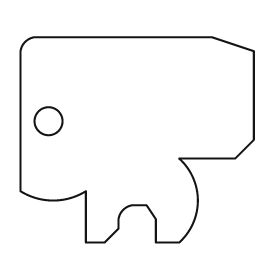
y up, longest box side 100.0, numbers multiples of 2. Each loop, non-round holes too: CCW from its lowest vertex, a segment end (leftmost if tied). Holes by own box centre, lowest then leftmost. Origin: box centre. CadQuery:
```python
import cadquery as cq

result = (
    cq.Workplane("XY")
    .moveTo(-22.0, -44.0)
    .lineTo(-14.0, -44.0)
    .lineTo(-8.0, -38.0)
    .lineTo(-8.0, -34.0)
    .threePointArc((-6.0, -30.0), (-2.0, -28.0))
    .lineTo(4.0, -28.0)
    .lineTo(8.0, -34.0)
    .lineTo(8.0, -44.0)
    .lineTo(18.0, -44.0)
    .threePointArc((26.0, -26.0), (18.0, -8.0))
    .lineTo(42.0, -8.0)
    .lineTo(50.0, 0.0)
    .lineTo(50.0, 38.0)
    .lineTo(32.0, 44.0)
    .lineTo(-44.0, 44.0)
    .threePointArc((-48.0, 42.0), (-50.0, 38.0))
    .lineTo(-50.0, -22.0)
    .threePointArc((-36.0, -26.0), (-22.0, -22.0))
    .close()
    .moveTo(-38.0, 8.0)
    .circle(6.0)
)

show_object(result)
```